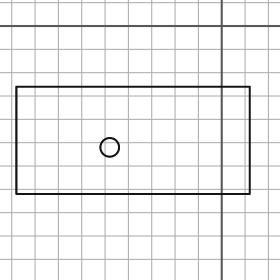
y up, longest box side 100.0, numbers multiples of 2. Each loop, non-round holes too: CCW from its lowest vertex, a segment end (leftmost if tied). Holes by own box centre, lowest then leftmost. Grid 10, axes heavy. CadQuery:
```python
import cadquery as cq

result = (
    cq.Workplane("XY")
    .moveTo(-88.0, -72.0)
    .lineTo(12.0, -72.0)
    .lineTo(12.0, -26.0)
    .lineTo(-88.0, -26.0)
    .close()
    .moveTo(-48.0, -52.0)
    .circle(4.0)
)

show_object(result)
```